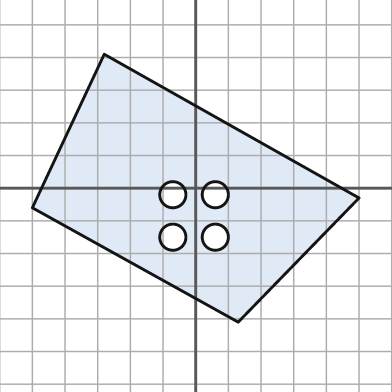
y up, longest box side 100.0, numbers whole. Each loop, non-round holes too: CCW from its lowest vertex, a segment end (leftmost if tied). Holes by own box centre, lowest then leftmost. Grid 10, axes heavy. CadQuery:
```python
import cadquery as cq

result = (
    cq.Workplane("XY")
    .moveTo(13.0, -41.0)
    .lineTo(50.0, -3.0)
    .lineTo(-28.0, 41.0)
    .lineTo(-50.0, -6.0)
    .close()
    .moveTo(-7.0, -15.0)
    .circle(4.0)
    .moveTo(6.0, -15.0)
    .circle(4.0)
    .moveTo(-7.0, -2.0)
    .circle(4.0)
    .moveTo(6.0, -2.0)
    .circle(4.0)
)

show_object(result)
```